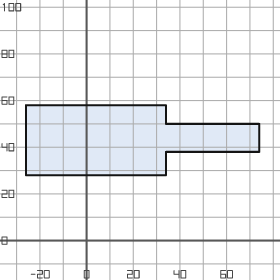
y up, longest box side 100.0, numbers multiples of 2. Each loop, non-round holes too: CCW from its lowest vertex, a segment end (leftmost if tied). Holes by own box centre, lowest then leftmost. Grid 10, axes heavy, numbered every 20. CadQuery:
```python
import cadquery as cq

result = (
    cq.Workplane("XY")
    .moveTo(-26.0, 28.0)
    .lineTo(34.0, 28.0)
    .lineTo(34.0, 38.0)
    .lineTo(74.0, 38.0)
    .lineTo(74.0, 50.0)
    .lineTo(34.0, 50.0)
    .lineTo(34.0, 58.0)
    .lineTo(-26.0, 58.0)
    .close()
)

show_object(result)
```